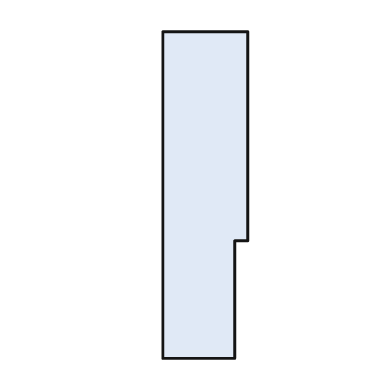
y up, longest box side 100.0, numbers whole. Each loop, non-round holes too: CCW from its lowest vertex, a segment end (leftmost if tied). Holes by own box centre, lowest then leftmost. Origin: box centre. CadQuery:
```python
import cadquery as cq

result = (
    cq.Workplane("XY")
    .moveTo(-13.0, -50.0)
    .lineTo(9.0, -50.0)
    .lineTo(9.0, -14.0)
    .lineTo(13.0, -14.0)
    .lineTo(13.0, 50.0)
    .lineTo(-13.0, 50.0)
    .close()
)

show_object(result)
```